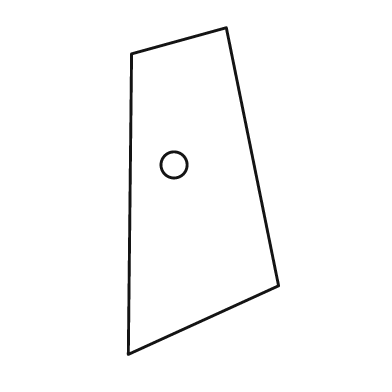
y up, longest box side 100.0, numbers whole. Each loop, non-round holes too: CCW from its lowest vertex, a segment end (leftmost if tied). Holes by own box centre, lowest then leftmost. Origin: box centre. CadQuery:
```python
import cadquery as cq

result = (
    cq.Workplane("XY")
    .moveTo(-23.0, -50.0)
    .lineTo(23.0, -29.0)
    .lineTo(7.0, 50.0)
    .lineTo(-22.0, 42.0)
    .close()
    .moveTo(-9.0, 8.0)
    .circle(4.0)
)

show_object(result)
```